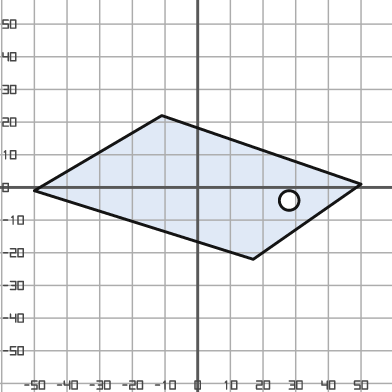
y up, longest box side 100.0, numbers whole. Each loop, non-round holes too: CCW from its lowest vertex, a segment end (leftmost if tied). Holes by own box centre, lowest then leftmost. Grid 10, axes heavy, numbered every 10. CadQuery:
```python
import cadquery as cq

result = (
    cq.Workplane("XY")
    .moveTo(17.0, -22.0)
    .lineTo(50.0, 1.0)
    .lineTo(-11.0, 22.0)
    .lineTo(-50.0, -1.0)
    .close()
    .moveTo(28.0, -4.0)
    .circle(3.0)
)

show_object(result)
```